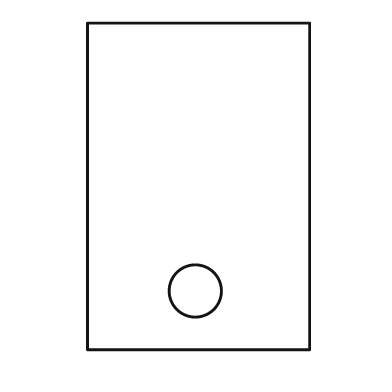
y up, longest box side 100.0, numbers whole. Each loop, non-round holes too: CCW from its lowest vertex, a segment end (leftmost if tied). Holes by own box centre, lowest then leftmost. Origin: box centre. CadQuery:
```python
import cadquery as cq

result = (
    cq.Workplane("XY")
    .moveTo(-34.0, -50.0)
    .lineTo(34.0, -50.0)
    .lineTo(34.0, 50.0)
    .lineTo(-34.0, 50.0)
    .close()
    .moveTo(-1.0, -32.0)
    .circle(8.0)
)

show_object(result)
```